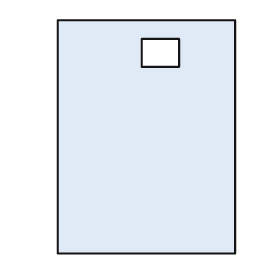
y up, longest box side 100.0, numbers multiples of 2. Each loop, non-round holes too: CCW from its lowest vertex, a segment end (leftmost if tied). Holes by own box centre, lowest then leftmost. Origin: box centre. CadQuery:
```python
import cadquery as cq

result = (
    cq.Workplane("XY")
    .moveTo(-38.0, -50.0)
    .lineTo(38.0, -50.0)
    .lineTo(38.0, 50.0)
    .lineTo(-38.0, 50.0)
    .close()
    .moveTo(-2.0, 30.0)
    .lineTo(14.0, 30.0)
    .lineTo(14.0, 42.0)
    .lineTo(-2.0, 42.0)
    .close()
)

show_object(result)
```